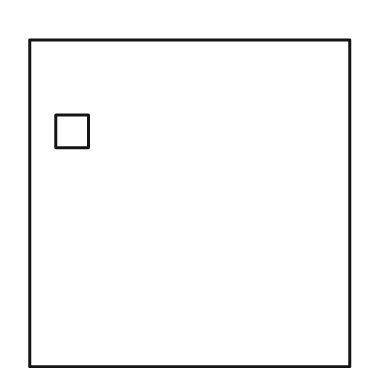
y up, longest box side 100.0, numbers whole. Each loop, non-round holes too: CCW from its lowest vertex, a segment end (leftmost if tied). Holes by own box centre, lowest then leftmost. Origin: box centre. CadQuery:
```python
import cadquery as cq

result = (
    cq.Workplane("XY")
    .moveTo(-49.0, -50.0)
    .lineTo(49.0, -50.0)
    .lineTo(49.0, 50.0)
    .lineTo(-49.0, 50.0)
    .close()
    .moveTo(-41.0, 17.0)
    .lineTo(-31.0, 17.0)
    .lineTo(-31.0, 27.0)
    .lineTo(-41.0, 27.0)
    .close()
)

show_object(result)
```